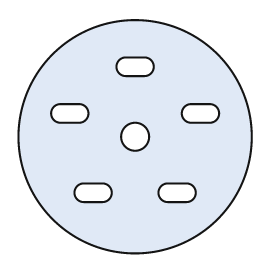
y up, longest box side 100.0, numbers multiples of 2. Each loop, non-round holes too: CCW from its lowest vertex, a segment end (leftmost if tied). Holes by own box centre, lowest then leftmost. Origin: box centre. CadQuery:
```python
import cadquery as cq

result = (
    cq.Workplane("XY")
    .moveTo(0.0, 0.0)
    .circle(50.0)
    .moveTo(-22.0, -28.0)
    .lineTo(-14.0, -28.0)
    .threePointArc((-10.0, -24.0), (-14.0, -20.0))
    .lineTo(-22.0, -20.0)
    .threePointArc((-26.0, -24.0), (-22.0, -28.0))
    .close()
    .moveTo(14.0, -28.0)
    .lineTo(22.0, -28.0)
    .threePointArc((26.0, -24.0), (22.0, -20.0))
    .lineTo(14.0, -20.0)
    .threePointArc((10.0, -24.0), (14.0, -28.0))
    .close()
    .moveTo(0.0, 0.0)
    .circle(6.0)
    .moveTo(-32.0, 6.0)
    .lineTo(-24.0, 6.0)
    .threePointArc((-20.0, 10.0), (-24.0, 14.0))
    .lineTo(-32.0, 14.0)
    .threePointArc((-36.0, 10.0), (-32.0, 6.0))
    .close()
    .moveTo(24.0, 6.0)
    .lineTo(32.0, 6.0)
    .threePointArc((36.0, 10.0), (32.0, 14.0))
    .lineTo(24.0, 14.0)
    .threePointArc((20.0, 10.0), (24.0, 6.0))
    .close()
    .moveTo(-4.0, 26.0)
    .lineTo(4.0, 26.0)
    .threePointArc((8.0, 30.0), (4.0, 34.0))
    .lineTo(-4.0, 34.0)
    .threePointArc((-8.0, 30.0), (-4.0, 26.0))
    .close()
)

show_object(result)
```